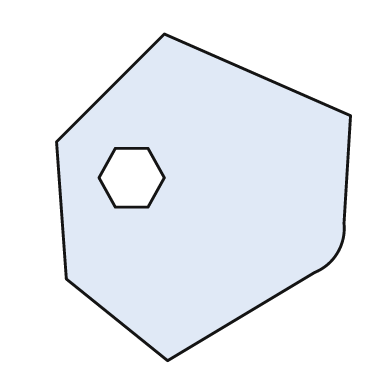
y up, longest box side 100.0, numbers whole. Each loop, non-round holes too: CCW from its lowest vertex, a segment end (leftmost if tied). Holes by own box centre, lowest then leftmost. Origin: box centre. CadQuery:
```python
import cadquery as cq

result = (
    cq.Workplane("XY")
    .moveTo(-11.0, -50.0)
    .lineTo(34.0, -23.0)
    .threePointArc((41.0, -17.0), (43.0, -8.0))
    .lineTo(45.0, 25.0)
    .lineTo(-12.0, 50.0)
    .lineTo(-45.0, 17.0)
    .lineTo(-42.0, -25.0)
    .close()
    .moveTo(-27.0, -3.0)
    .lineTo(-17.0, -3.0)
    .lineTo(-12.0, 6.0)
    .lineTo(-17.0, 15.0)
    .lineTo(-27.0, 15.0)
    .lineTo(-32.0, 6.0)
    .close()
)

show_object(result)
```